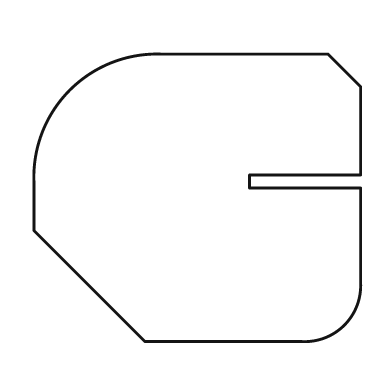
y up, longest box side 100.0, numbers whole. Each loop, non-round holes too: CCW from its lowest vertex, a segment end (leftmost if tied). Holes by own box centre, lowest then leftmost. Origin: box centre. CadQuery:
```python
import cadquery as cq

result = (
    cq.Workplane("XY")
    .moveTo(-16.0, -44.0)
    .lineTo(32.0, -44.0)
    .threePointArc((45.0, -39.0), (50.0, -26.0))
    .lineTo(50.0, 3.0)
    .lineTo(16.0, 3.0)
    .lineTo(16.0, 7.0)
    .lineTo(50.0, 7.0)
    .lineTo(50.0, 34.0)
    .lineTo(40.0, 44.0)
    .lineTo(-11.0, 44.0)
    .threePointArc((-39.0, 33.0), (-50.0, 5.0))
    .lineTo(-50.0, -10.0)
    .close()
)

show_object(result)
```